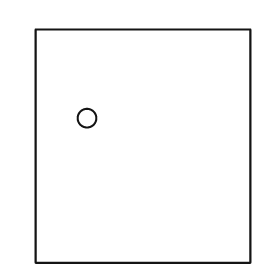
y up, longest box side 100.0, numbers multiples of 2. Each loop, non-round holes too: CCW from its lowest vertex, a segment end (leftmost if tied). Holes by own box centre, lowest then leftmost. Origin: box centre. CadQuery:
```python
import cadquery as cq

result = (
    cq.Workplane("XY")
    .moveTo(-46.0, -50.0)
    .lineTo(46.0, -50.0)
    .lineTo(46.0, 50.0)
    .lineTo(-46.0, 50.0)
    .close()
    .moveTo(-24.0, 12.0)
    .circle(4.0)
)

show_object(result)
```